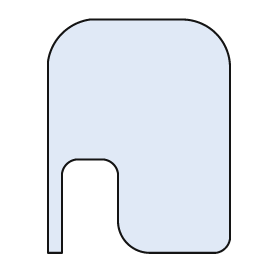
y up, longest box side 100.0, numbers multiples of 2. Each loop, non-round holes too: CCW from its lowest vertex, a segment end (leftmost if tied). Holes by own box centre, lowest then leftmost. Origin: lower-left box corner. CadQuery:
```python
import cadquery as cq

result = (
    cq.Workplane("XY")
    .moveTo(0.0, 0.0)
    .lineTo(6.0, 0.0)
    .lineTo(6.0, 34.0)
    .threePointArc((8.0, 38.0), (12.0, 40.0))
    .lineTo(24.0, 40.0)
    .threePointArc((28.0, 38.0), (30.0, 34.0))
    .lineTo(30.0, 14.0)
    .threePointArc((34.0, 4.0), (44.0, 0.0))
    .lineTo(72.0, 0.0)
    .threePointArc((76.0, 2.0), (78.0, 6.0))
    .lineTo(78.0, 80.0)
    .threePointArc((72.0, 94.0), (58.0, 100.0))
    .lineTo(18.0, 100.0)
    .threePointArc((6.0, 94.0), (0.0, 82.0))
    .close()
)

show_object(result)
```